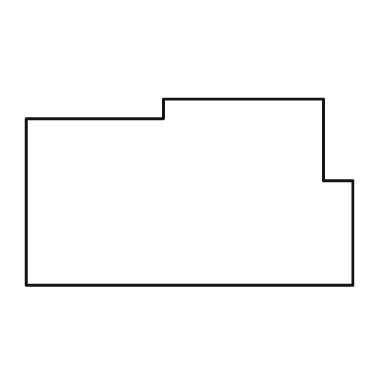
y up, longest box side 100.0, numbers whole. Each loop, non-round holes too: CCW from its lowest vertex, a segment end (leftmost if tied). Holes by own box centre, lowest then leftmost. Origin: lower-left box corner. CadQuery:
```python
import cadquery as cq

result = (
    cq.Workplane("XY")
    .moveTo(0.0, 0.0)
    .lineTo(100.0, 0.0)
    .lineTo(100.0, 32.0)
    .lineTo(91.0, 32.0)
    .lineTo(91.0, 57.0)
    .lineTo(42.0, 57.0)
    .lineTo(42.0, 51.0)
    .lineTo(0.0, 51.0)
    .close()
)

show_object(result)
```